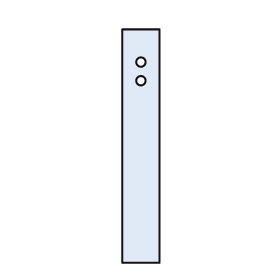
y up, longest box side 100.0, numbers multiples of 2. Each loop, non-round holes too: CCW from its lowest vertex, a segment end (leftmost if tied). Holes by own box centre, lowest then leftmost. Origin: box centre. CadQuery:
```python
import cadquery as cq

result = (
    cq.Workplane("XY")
    .moveTo(-8.0, -50.0)
    .lineTo(8.0, -50.0)
    .lineTo(8.0, 50.0)
    .lineTo(-8.0, 50.0)
    .close()
    .moveTo(0.0, 28.0)
    .circle(2.0)
    .moveTo(0.0, 36.0)
    .circle(2.0)
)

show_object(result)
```